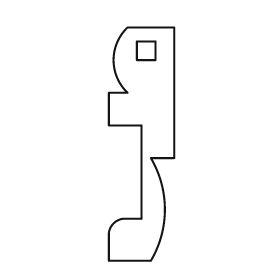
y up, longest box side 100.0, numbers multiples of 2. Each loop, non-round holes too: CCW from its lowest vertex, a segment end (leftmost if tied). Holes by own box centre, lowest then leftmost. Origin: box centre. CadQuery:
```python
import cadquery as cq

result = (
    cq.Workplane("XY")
    .moveTo(-14.0, -50.0)
    .lineTo(4.0, -50.0)
    .threePointArc((10.0, -28.0), (4.0, -6.0))
    .lineTo(14.0, -6.0)
    .lineTo(14.0, 50.0)
    .lineTo(-6.0, 50.0)
    .threePointArc((-12.0, 36.0), (-6.0, 22.0))
    .lineTo(-14.0, 22.0)
    .lineTo(-14.0, 8.0)
    .lineTo(0.0, 8.0)
    .lineTo(0.0, -32.0)
    .lineTo(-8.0, -32.0)
    .threePointArc((-12.0, -34.0), (-14.0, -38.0))
    .close()
    .moveTo(-2.0, 36.0)
    .lineTo(6.0, 36.0)
    .lineTo(6.0, 44.0)
    .lineTo(-2.0, 44.0)
    .close()
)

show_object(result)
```